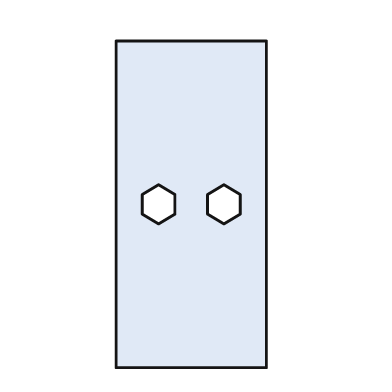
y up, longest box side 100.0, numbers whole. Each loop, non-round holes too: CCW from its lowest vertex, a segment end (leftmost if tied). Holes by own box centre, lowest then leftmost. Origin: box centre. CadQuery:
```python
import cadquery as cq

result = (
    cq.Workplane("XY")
    .moveTo(-23.0, -50.0)
    .lineTo(23.0, -50.0)
    .lineTo(23.0, 50.0)
    .lineTo(-23.0, 50.0)
    .close()
    .moveTo(-10.0, -6.0)
    .lineTo(-5.0, -3.0)
    .lineTo(-5.0, 3.0)
    .lineTo(-10.0, 6.0)
    .lineTo(-15.0, 3.0)
    .lineTo(-15.0, -3.0)
    .close()
    .moveTo(10.0, -6.0)
    .lineTo(15.0, -3.0)
    .lineTo(15.0, 3.0)
    .lineTo(10.0, 6.0)
    .lineTo(5.0, 3.0)
    .lineTo(5.0, -3.0)
    .close()
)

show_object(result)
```